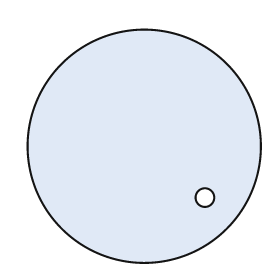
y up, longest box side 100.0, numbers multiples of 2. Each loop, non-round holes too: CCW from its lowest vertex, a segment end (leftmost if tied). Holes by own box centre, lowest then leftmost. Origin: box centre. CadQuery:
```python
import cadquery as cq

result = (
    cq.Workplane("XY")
    .moveTo(0.0, 0.0)
    .circle(50.0)
    .moveTo(26.0, -22.0)
    .circle(4.0)
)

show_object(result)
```